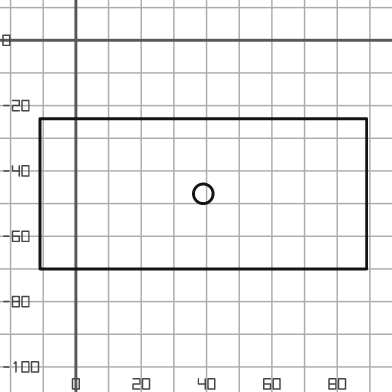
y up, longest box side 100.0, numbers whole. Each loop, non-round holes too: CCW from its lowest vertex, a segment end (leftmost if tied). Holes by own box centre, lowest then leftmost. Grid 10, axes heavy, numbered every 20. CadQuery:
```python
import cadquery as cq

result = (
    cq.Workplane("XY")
    .moveTo(-11.0, -70.0)
    .lineTo(89.0, -70.0)
    .lineTo(89.0, -24.0)
    .lineTo(-11.0, -24.0)
    .close()
    .moveTo(39.0, -47.0)
    .circle(3.0)
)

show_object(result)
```